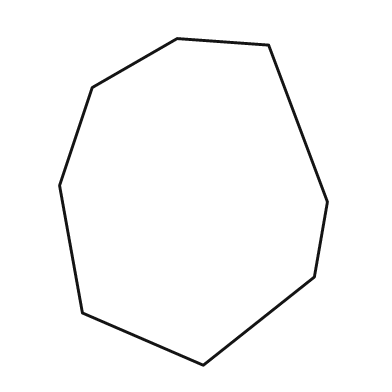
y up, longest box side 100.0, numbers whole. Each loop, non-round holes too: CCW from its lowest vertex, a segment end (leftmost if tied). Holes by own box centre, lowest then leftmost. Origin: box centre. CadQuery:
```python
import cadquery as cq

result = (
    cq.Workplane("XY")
    .moveTo(3.0, -50.0)
    .lineTo(37.0, -23.0)
    .lineTo(41.0, 0.0)
    .lineTo(23.0, 48.0)
    .lineTo(-5.0, 50.0)
    .lineTo(-31.0, 35.0)
    .lineTo(-41.0, 5.0)
    .lineTo(-34.0, -34.0)
    .close()
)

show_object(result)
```